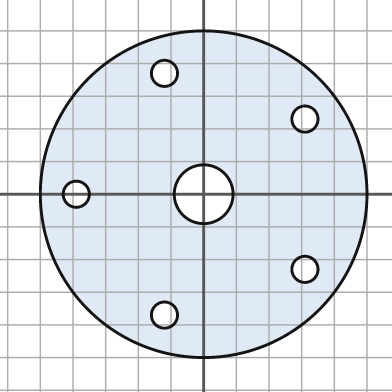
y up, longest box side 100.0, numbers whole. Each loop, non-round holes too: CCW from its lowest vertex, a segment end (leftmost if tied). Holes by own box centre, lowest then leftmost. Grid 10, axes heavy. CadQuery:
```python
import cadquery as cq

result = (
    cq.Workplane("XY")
    .moveTo(0.0, 0.0)
    .circle(50.0)
    .moveTo(-12.0, -37.0)
    .circle(4.0)
    .moveTo(31.0, -23.0)
    .circle(4.0)
    .moveTo(-39.0, 0.0)
    .circle(4.0)
    .moveTo(0.0, 0.0)
    .circle(9.0)
    .moveTo(31.0, 23.0)
    .circle(4.0)
    .moveTo(-12.0, 37.0)
    .circle(4.0)
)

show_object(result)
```